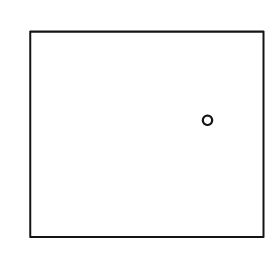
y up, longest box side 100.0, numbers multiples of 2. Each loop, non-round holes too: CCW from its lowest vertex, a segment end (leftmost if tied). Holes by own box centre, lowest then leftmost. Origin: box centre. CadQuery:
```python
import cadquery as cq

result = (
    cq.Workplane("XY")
    .moveTo(-50.0, -44.0)
    .lineTo(50.0, -44.0)
    .lineTo(50.0, 44.0)
    .lineTo(-50.0, 44.0)
    .close()
    .moveTo(26.0, 6.0)
    .circle(2.0)
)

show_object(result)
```